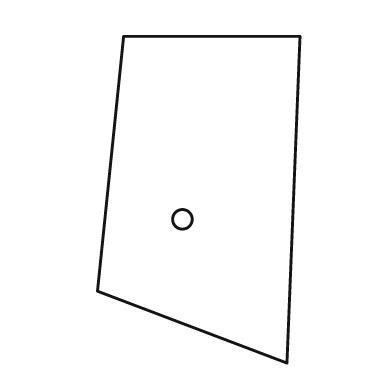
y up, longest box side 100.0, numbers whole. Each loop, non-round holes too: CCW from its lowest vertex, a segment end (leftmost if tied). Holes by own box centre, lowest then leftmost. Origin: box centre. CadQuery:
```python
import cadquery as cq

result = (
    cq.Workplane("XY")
    .moveTo(27.0, -50.0)
    .lineTo(31.0, 50.0)
    .lineTo(-23.0, 50.0)
    .lineTo(-31.0, -28.0)
    .close()
    .moveTo(-5.0, -6.0)
    .circle(3.0)
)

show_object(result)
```